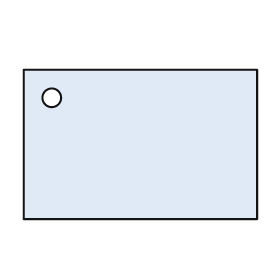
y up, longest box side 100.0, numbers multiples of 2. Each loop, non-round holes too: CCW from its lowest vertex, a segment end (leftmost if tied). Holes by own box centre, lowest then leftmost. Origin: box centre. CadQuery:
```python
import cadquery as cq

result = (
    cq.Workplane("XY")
    .moveTo(-50.0, -32.0)
    .lineTo(50.0, -32.0)
    .lineTo(50.0, 32.0)
    .lineTo(-50.0, 32.0)
    .close()
    .moveTo(-38.0, 20.0)
    .circle(4.0)
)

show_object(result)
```